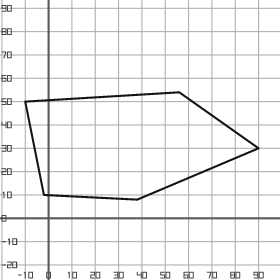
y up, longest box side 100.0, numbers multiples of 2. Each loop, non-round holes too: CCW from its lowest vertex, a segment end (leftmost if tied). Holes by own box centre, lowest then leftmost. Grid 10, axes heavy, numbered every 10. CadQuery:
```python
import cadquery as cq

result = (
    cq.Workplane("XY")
    .moveTo(38.0, 8.0)
    .lineTo(90.0, 30.0)
    .lineTo(56.0, 54.0)
    .lineTo(-10.0, 50.0)
    .lineTo(-2.0, 10.0)
    .close()
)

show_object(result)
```